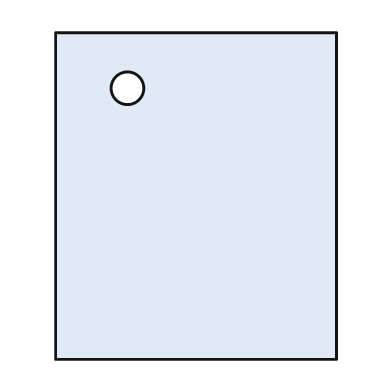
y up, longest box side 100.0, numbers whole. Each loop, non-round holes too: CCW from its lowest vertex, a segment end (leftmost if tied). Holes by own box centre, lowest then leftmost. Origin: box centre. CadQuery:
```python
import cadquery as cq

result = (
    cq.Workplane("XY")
    .moveTo(-43.0, -50.0)
    .lineTo(43.0, -50.0)
    .lineTo(43.0, 50.0)
    .lineTo(-43.0, 50.0)
    .close()
    .moveTo(-21.0, 33.0)
    .circle(5.0)
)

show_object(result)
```